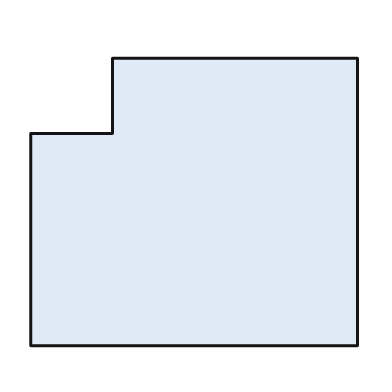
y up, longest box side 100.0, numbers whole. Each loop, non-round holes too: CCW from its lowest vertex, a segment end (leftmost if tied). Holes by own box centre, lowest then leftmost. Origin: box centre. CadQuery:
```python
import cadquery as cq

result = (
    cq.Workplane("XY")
    .moveTo(-50.0, -44.0)
    .lineTo(50.0, -44.0)
    .lineTo(50.0, 44.0)
    .lineTo(-25.0, 44.0)
    .lineTo(-25.0, 21.0)
    .lineTo(-50.0, 21.0)
    .close()
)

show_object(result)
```